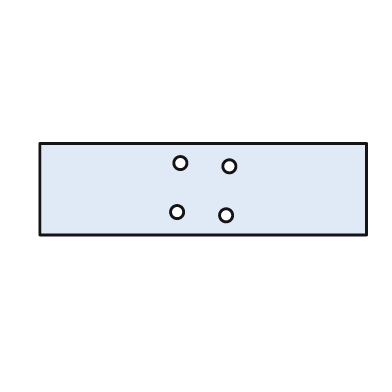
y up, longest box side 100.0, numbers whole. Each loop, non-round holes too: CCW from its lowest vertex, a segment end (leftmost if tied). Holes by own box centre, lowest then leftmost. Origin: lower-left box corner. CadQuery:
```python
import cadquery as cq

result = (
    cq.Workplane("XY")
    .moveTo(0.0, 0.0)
    .lineTo(100.0, 0.0)
    .lineTo(100.0, 28.0)
    .lineTo(0.0, 28.0)
    .close()
    .moveTo(57.0, 6.0)
    .circle(2.0)
    .moveTo(42.0, 7.0)
    .circle(2.0)
    .moveTo(58.0, 21.0)
    .circle(2.0)
    .moveTo(43.0, 22.0)
    .circle(2.0)
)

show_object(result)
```